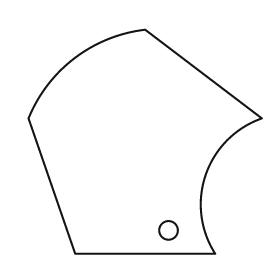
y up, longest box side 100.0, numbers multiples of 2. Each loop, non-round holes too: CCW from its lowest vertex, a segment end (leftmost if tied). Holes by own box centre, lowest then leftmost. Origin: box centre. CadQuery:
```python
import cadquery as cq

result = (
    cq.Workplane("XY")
    .moveTo(-30.0, -48.0)
    .lineTo(30.0, -48.0)
    .threePointArc((26.0, -14.0), (50.0, 10.0))
    .lineTo(0.0, 48.0)
    .threePointArc((-30.0, 36.0), (-50.0, 10.0))
    .close()
    .moveTo(10.0, -38.0)
    .circle(4.0)
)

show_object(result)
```